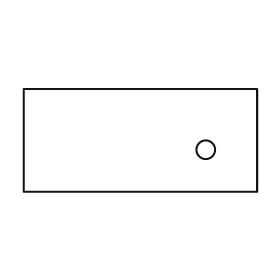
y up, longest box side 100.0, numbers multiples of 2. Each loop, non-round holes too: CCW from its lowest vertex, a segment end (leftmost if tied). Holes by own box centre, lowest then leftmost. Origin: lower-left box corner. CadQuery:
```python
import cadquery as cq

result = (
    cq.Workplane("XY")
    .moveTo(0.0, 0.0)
    .lineTo(100.0, 0.0)
    .lineTo(100.0, 44.0)
    .lineTo(0.0, 44.0)
    .close()
    .moveTo(78.0, 18.0)
    .circle(4.0)
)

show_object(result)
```